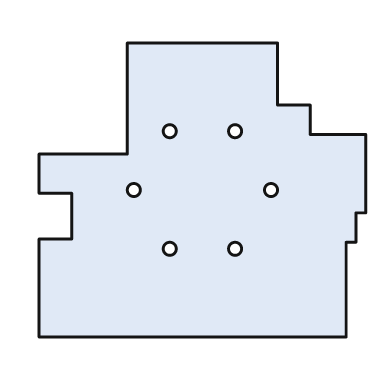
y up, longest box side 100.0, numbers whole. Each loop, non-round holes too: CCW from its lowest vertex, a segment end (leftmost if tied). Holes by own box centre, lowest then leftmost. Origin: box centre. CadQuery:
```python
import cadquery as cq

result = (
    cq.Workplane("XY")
    .moveTo(-50.0, -45.0)
    .lineTo(44.0, -45.0)
    .lineTo(44.0, -16.0)
    .lineTo(47.0, -16.0)
    .lineTo(47.0, -7.0)
    .lineTo(50.0, -7.0)
    .lineTo(50.0, 17.0)
    .lineTo(33.0, 17.0)
    .lineTo(33.0, 26.0)
    .lineTo(23.0, 26.0)
    .lineTo(23.0, 45.0)
    .lineTo(-23.0, 45.0)
    .lineTo(-23.0, 11.0)
    .lineTo(-50.0, 11.0)
    .lineTo(-50.0, -1.0)
    .lineTo(-40.0, -1.0)
    .lineTo(-40.0, -15.0)
    .lineTo(-50.0, -15.0)
    .close()
    .moveTo(-10.0, -18.0)
    .circle(2.0)
    .moveTo(10.0, -18.0)
    .circle(2.0)
    .moveTo(-21.0, 0.0)
    .circle(2.0)
    .moveTo(21.0, 0.0)
    .circle(2.0)
    .moveTo(-10.0, 18.0)
    .circle(2.0)
    .moveTo(10.0, 18.0)
    .circle(2.0)
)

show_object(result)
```